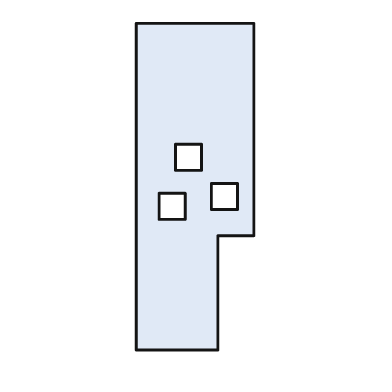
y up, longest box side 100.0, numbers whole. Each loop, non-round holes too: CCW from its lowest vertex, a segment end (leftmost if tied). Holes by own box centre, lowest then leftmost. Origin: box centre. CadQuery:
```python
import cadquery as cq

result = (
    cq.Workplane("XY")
    .moveTo(-18.0, -50.0)
    .lineTo(7.0, -50.0)
    .lineTo(7.0, -15.0)
    .lineTo(18.0, -15.0)
    .lineTo(18.0, 50.0)
    .lineTo(-18.0, 50.0)
    .close()
    .moveTo(-11.0, -10.0)
    .lineTo(-3.0, -10.0)
    .lineTo(-3.0, -2.0)
    .lineTo(-11.0, -2.0)
    .close()
    .moveTo(5.0, -7.0)
    .lineTo(13.0, -7.0)
    .lineTo(13.0, 1.0)
    .lineTo(5.0, 1.0)
    .close()
    .moveTo(-6.0, 5.0)
    .lineTo(2.0, 5.0)
    .lineTo(2.0, 13.0)
    .lineTo(-6.0, 13.0)
    .close()
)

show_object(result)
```